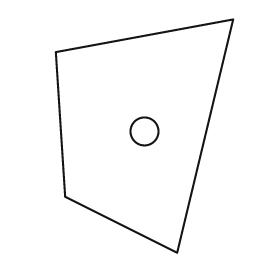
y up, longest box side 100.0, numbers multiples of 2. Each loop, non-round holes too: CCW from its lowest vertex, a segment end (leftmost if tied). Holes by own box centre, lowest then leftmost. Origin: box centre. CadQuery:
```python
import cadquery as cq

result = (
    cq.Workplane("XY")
    .moveTo(14.0, -50.0)
    .lineTo(38.0, 50.0)
    .lineTo(-38.0, 36.0)
    .lineTo(-34.0, -26.0)
    .close()
    .moveTo(0.0, 2.0)
    .circle(6.0)
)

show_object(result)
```